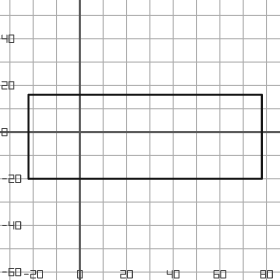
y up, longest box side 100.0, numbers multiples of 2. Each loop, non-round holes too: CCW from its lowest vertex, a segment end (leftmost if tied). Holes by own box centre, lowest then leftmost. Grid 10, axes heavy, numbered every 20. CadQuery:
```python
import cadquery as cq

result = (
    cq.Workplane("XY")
    .moveTo(-22.0, -20.0)
    .lineTo(78.0, -20.0)
    .lineTo(78.0, 16.0)
    .lineTo(-22.0, 16.0)
    .close()
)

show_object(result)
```